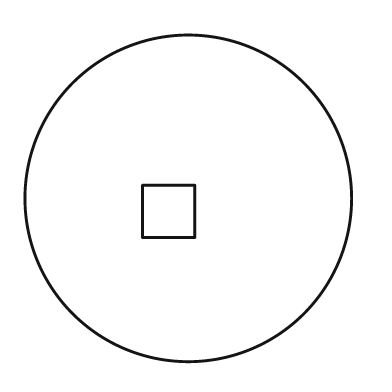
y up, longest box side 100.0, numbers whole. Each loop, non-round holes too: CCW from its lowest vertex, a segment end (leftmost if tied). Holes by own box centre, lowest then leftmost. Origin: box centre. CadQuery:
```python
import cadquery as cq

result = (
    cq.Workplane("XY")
    .moveTo(0.0, 0.0)
    .circle(50.0)
    .moveTo(-14.0, -12.0)
    .lineTo(2.0, -12.0)
    .lineTo(2.0, 4.0)
    .lineTo(-14.0, 4.0)
    .close()
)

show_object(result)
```